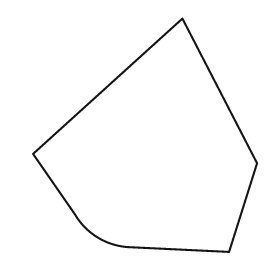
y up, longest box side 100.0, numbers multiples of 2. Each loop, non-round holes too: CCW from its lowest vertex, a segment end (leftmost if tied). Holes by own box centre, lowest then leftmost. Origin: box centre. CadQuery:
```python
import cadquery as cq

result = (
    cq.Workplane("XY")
    .moveTo(36.0, -50.0)
    .lineTo(48.0, -12.0)
    .lineTo(16.0, 50.0)
    .lineTo(-48.0, -8.0)
    .lineTo(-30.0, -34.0)
    .threePointArc((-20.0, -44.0), (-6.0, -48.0))
    .close()
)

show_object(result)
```